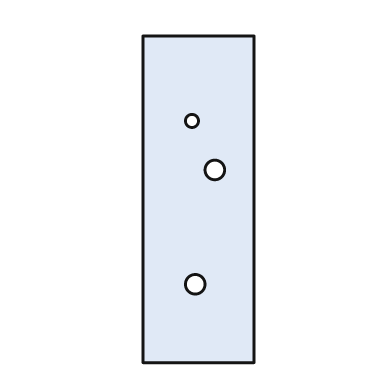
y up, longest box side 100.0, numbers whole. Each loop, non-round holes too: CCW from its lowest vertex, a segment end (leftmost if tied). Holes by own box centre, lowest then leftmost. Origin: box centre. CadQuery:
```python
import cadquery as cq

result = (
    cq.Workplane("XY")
    .moveTo(-17.0, -50.0)
    .lineTo(17.0, -50.0)
    .lineTo(17.0, 50.0)
    .lineTo(-17.0, 50.0)
    .close()
    .moveTo(-1.0, -26.0)
    .circle(3.0)
    .moveTo(5.0, 9.0)
    .circle(3.0)
    .moveTo(-2.0, 24.0)
    .circle(2.0)
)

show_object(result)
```